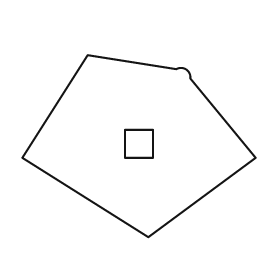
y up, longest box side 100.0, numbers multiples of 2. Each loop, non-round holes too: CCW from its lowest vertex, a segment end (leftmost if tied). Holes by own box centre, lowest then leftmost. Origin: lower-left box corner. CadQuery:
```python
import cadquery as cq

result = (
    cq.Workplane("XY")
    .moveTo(54.0, 0.0)
    .lineTo(100.0, 34.0)
    .lineTo(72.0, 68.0)
    .threePointArc((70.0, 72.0), (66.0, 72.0))
    .lineTo(28.0, 78.0)
    .lineTo(0.0, 34.0)
    .close()
    .moveTo(44.0, 34.0)
    .lineTo(56.0, 34.0)
    .lineTo(56.0, 46.0)
    .lineTo(44.0, 46.0)
    .close()
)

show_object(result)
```